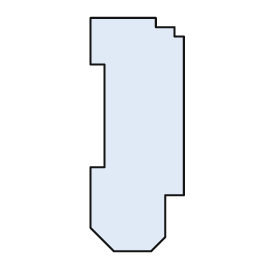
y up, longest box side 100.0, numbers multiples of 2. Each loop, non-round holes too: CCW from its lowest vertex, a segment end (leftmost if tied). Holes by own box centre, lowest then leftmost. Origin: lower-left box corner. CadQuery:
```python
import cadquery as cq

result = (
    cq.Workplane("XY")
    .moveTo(10.0, 0.0)
    .lineTo(26.0, 0.0)
    .lineTo(32.0, 6.0)
    .lineTo(32.0, 24.0)
    .lineTo(40.0, 24.0)
    .lineTo(40.0, 92.0)
    .lineTo(36.0, 92.0)
    .lineTo(36.0, 96.0)
    .lineTo(28.0, 96.0)
    .lineTo(28.0, 100.0)
    .lineTo(0.0, 100.0)
    .lineTo(0.0, 80.0)
    .lineTo(6.0, 80.0)
    .lineTo(6.0, 36.0)
    .lineTo(0.0, 36.0)
    .lineTo(0.0, 10.0)
    .close()
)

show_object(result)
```